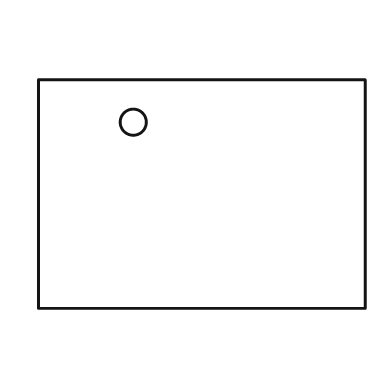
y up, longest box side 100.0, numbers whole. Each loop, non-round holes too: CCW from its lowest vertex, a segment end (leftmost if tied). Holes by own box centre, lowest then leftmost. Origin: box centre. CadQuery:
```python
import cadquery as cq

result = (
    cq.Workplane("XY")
    .moveTo(-50.0, -35.0)
    .lineTo(50.0, -35.0)
    .lineTo(50.0, 35.0)
    .lineTo(-50.0, 35.0)
    .close()
    .moveTo(-21.0, 22.0)
    .circle(4.0)
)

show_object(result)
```